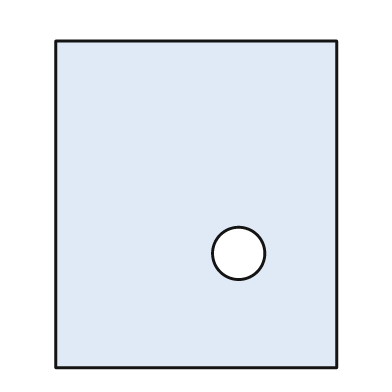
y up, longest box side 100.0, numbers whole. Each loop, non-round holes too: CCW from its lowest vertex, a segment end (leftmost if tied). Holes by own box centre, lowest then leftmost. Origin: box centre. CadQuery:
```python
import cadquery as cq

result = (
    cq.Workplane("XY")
    .moveTo(-43.0, -50.0)
    .lineTo(43.0, -50.0)
    .lineTo(43.0, 50.0)
    .lineTo(-43.0, 50.0)
    .close()
    .moveTo(13.0, -15.0)
    .circle(8.0)
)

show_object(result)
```